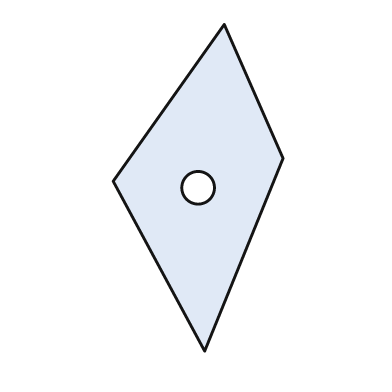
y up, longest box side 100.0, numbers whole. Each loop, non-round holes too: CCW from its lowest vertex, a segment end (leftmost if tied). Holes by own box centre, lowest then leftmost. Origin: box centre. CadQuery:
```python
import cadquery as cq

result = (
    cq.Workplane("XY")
    .moveTo(2.0, -50.0)
    .lineTo(26.0, 9.0)
    .lineTo(8.0, 50.0)
    .lineTo(-26.0, 2.0)
    .close()
    .moveTo(0.0, 0.0)
    .circle(5.0)
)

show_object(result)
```